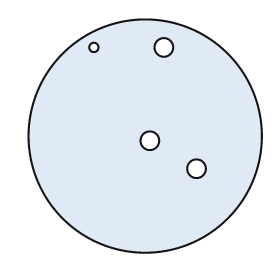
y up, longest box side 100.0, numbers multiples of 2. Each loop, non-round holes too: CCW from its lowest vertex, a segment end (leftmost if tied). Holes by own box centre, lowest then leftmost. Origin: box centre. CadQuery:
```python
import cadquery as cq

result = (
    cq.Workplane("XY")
    .moveTo(0.0, 0.0)
    .circle(50.0)
    .moveTo(22.0, -14.0)
    .circle(4.0)
    .moveTo(2.0, -2.0)
    .circle(4.0)
    .moveTo(-22.0, 38.0)
    .circle(2.0)
    .moveTo(8.0, 38.0)
    .circle(4.0)
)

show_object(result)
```